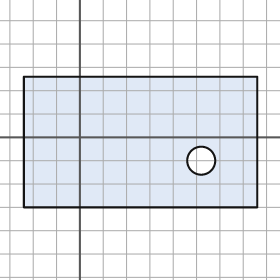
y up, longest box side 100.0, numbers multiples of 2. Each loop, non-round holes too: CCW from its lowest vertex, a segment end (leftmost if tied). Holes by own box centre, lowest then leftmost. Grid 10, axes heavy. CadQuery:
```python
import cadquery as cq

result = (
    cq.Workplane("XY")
    .moveTo(-24.0, -30.0)
    .lineTo(76.0, -30.0)
    .lineTo(76.0, 26.0)
    .lineTo(-24.0, 26.0)
    .close()
    .moveTo(52.0, -10.0)
    .circle(6.0)
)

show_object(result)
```